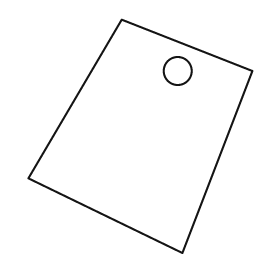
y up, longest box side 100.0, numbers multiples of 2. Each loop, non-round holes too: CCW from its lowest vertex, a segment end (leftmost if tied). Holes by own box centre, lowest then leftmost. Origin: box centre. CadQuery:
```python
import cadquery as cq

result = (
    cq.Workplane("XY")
    .moveTo(18.0, -50.0)
    .lineTo(48.0, 28.0)
    .lineTo(-8.0, 50.0)
    .lineTo(-48.0, -18.0)
    .close()
    .moveTo(16.0, 28.0)
    .circle(6.0)
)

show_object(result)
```